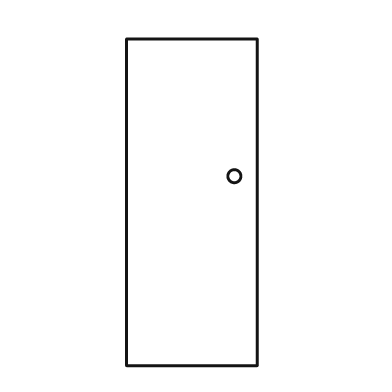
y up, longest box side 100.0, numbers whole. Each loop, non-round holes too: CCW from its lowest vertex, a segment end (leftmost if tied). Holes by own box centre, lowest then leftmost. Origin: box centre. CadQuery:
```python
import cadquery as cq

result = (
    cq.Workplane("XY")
    .moveTo(-20.0, -50.0)
    .lineTo(20.0, -50.0)
    .lineTo(20.0, 50.0)
    .lineTo(-20.0, 50.0)
    .close()
    .moveTo(13.0, 8.0)
    .circle(2.0)
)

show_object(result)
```